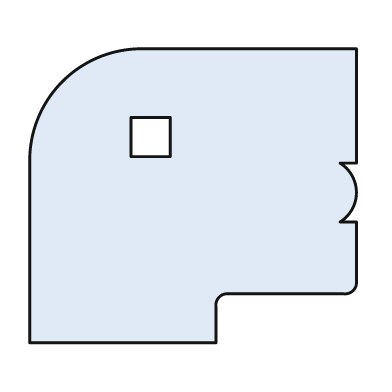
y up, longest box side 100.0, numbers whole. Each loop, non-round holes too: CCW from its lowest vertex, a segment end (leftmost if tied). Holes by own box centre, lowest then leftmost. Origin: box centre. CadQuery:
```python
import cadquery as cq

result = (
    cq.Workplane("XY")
    .moveTo(-50.0, -45.0)
    .lineTo(7.0, -45.0)
    .lineTo(7.0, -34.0)
    .threePointArc((8.0, -31.0), (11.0, -30.0))
    .lineTo(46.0, -30.0)
    .threePointArc((49.0, -29.0), (50.0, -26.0))
    .lineTo(50.0, -8.0)
    .lineTo(45.0, -8.0)
    .threePointArc((50.0, 1.0), (45.0, 10.0))
    .lineTo(50.0, 10.0)
    .lineTo(50.0, 45.0)
    .lineTo(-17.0, 45.0)
    .threePointArc((-40.0, 35.0), (-50.0, 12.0))
    .close()
    .moveTo(-19.0, 12.0)
    .lineTo(-7.0, 12.0)
    .lineTo(-7.0, 24.0)
    .lineTo(-19.0, 24.0)
    .close()
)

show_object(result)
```